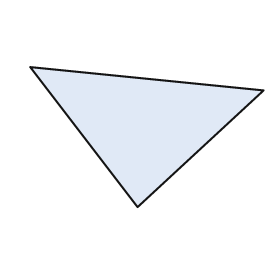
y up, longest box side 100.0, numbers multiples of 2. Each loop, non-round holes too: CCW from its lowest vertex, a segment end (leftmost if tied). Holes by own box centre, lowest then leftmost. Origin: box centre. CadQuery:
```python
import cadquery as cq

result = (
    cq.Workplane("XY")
    .moveTo(-4.0, -30.0)
    .lineTo(50.0, 20.0)
    .lineTo(-50.0, 30.0)
    .close()
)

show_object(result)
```